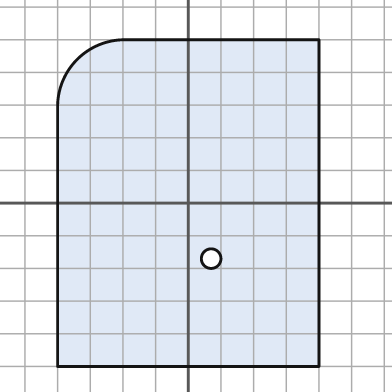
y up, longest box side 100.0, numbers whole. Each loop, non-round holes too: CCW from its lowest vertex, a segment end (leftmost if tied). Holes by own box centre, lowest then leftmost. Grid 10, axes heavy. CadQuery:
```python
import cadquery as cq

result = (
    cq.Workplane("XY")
    .moveTo(-40.0, -50.0)
    .lineTo(40.0, -50.0)
    .lineTo(40.0, 50.0)
    .lineTo(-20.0, 50.0)
    .threePointArc((-34.0, 44.0), (-40.0, 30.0))
    .close()
    .moveTo(7.0, -17.0)
    .circle(3.0)
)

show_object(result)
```